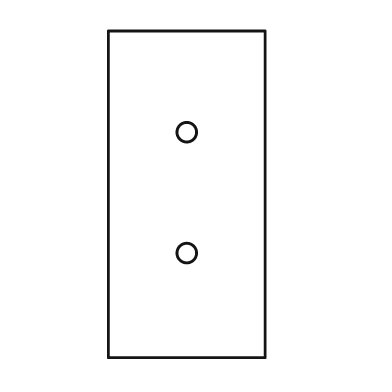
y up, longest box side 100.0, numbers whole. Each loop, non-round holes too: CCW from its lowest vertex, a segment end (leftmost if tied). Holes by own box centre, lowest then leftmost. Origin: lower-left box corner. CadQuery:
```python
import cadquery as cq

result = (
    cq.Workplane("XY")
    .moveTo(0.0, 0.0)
    .lineTo(48.0, 0.0)
    .lineTo(48.0, 100.0)
    .lineTo(0.0, 100.0)
    .close()
    .moveTo(24.0, 32.0)
    .circle(3.0)
    .moveTo(24.0, 69.0)
    .circle(3.0)
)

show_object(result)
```